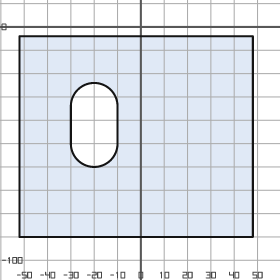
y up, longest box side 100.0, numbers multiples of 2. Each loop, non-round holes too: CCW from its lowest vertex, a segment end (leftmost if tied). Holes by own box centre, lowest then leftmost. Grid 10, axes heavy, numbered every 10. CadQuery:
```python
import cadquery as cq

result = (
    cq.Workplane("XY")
    .moveTo(-52.0, -90.0)
    .lineTo(48.0, -90.0)
    .lineTo(48.0, -4.0)
    .lineTo(-52.0, -4.0)
    .close()
    .moveTo(-30.0, -50.0)
    .threePointArc((-20.0, -60.0), (-10.0, -50.0))
    .lineTo(-10.0, -34.0)
    .threePointArc((-20.0, -24.0), (-30.0, -34.0))
    .close()
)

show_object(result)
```